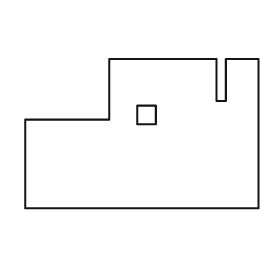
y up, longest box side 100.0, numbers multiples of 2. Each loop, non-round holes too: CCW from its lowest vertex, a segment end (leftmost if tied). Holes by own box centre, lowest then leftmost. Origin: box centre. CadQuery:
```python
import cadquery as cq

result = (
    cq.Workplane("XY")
    .moveTo(-50.0, -32.0)
    .lineTo(50.0, -32.0)
    .lineTo(50.0, 32.0)
    .lineTo(36.0, 32.0)
    .lineTo(36.0, 14.0)
    .lineTo(32.0, 14.0)
    .lineTo(32.0, 32.0)
    .lineTo(-14.0, 32.0)
    .lineTo(-14.0, 6.0)
    .lineTo(-50.0, 6.0)
    .close()
    .moveTo(-2.0, 4.0)
    .lineTo(6.0, 4.0)
    .lineTo(6.0, 12.0)
    .lineTo(-2.0, 12.0)
    .close()
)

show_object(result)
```